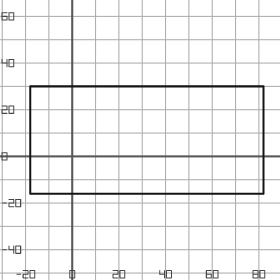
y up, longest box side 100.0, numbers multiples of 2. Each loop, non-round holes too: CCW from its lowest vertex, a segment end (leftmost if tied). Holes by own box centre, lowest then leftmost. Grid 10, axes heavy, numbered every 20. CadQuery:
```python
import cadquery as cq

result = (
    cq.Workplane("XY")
    .moveTo(-18.0, -16.0)
    .lineTo(82.0, -16.0)
    .lineTo(82.0, 30.0)
    .lineTo(-18.0, 30.0)
    .close()
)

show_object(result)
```